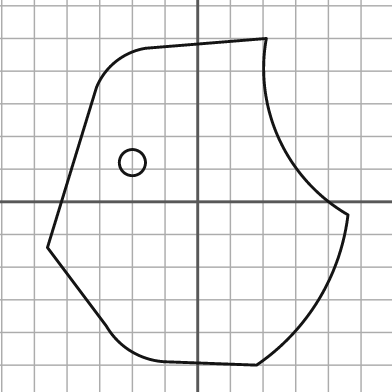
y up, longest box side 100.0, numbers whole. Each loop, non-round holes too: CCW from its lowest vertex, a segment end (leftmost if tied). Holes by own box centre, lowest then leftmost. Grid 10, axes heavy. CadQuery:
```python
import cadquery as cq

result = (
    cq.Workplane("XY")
    .moveTo(18.0, -50.0)
    .threePointArc((37.0, -30.0), (46.0, -4.0))
    .threePointArc((25.0, 19.0), (21.0, 50.0))
    .lineTo(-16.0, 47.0)
    .threePointArc((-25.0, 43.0), (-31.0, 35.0))
    .lineTo(-46.0, -14.0)
    .lineTo(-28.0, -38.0)
    .threePointArc((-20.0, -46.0), (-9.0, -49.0))
    .close()
    .moveTo(-20.0, 12.0)
    .circle(4.0)
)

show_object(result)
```